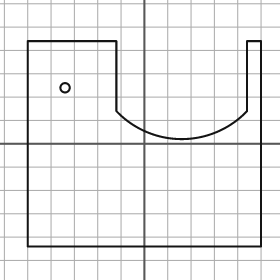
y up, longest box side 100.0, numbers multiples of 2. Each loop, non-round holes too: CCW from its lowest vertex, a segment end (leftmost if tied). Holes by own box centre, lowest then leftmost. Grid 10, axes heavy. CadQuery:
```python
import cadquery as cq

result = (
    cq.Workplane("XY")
    .moveTo(-50.0, -44.0)
    .lineTo(50.0, -44.0)
    .lineTo(50.0, 44.0)
    .lineTo(44.0, 44.0)
    .lineTo(44.0, 14.0)
    .threePointArc((16.0, 2.0), (-12.0, 14.0))
    .lineTo(-12.0, 44.0)
    .lineTo(-50.0, 44.0)
    .close()
    .moveTo(-34.0, 24.0)
    .circle(2.0)
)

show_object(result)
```